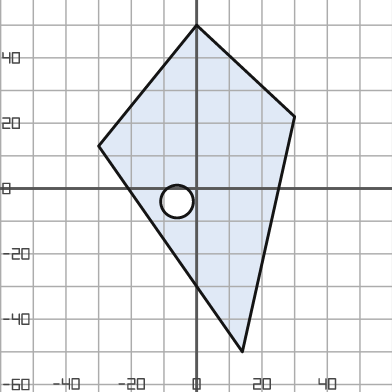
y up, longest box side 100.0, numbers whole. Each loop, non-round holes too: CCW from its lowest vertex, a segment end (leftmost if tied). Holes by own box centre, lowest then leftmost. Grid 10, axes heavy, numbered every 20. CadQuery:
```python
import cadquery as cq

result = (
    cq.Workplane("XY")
    .moveTo(14.0, -50.0)
    .lineTo(30.0, 22.0)
    .lineTo(0.0, 50.0)
    .lineTo(-30.0, 13.0)
    .close()
    .moveTo(-6.0, -4.0)
    .circle(5.0)
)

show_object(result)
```